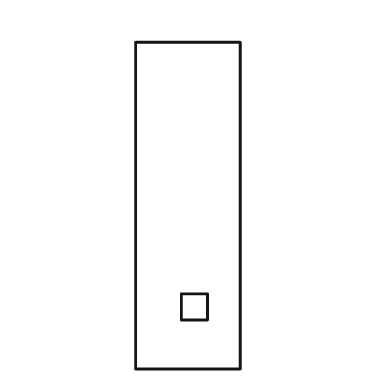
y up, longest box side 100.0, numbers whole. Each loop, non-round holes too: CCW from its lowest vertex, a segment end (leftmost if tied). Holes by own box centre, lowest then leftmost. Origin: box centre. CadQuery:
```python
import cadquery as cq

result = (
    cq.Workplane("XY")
    .moveTo(-16.0, -50.0)
    .lineTo(16.0, -50.0)
    .lineTo(16.0, 50.0)
    .lineTo(-16.0, 50.0)
    .close()
    .moveTo(-2.0, -35.0)
    .lineTo(6.0, -35.0)
    .lineTo(6.0, -27.0)
    .lineTo(-2.0, -27.0)
    .close()
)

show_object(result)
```